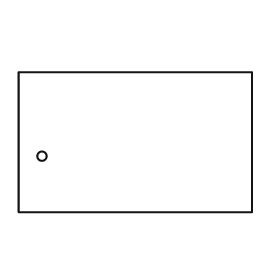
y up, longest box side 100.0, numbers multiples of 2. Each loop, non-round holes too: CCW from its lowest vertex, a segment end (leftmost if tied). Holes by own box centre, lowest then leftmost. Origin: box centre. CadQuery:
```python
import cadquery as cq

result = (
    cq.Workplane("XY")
    .moveTo(-50.0, -30.0)
    .lineTo(50.0, -30.0)
    .lineTo(50.0, 30.0)
    .lineTo(-50.0, 30.0)
    .close()
    .moveTo(-40.0, -6.0)
    .circle(2.0)
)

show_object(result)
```